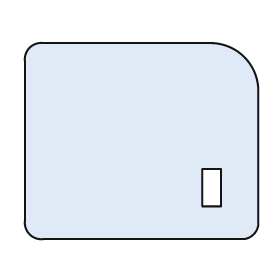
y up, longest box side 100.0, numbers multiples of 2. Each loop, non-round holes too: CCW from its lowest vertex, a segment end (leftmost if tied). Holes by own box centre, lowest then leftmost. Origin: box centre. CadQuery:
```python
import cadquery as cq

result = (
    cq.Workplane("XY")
    .moveTo(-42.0, -42.0)
    .lineTo(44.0, -42.0)
    .threePointArc((48.0, -40.0), (50.0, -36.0))
    .lineTo(50.0, 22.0)
    .threePointArc((44.0, 36.0), (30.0, 42.0))
    .lineTo(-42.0, 42.0)
    .threePointArc((-48.0, 40.0), (-50.0, 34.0))
    .lineTo(-50.0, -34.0)
    .threePointArc((-48.0, -40.0), (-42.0, -42.0))
    .close()
    .moveTo(26.0, -28.0)
    .lineTo(34.0, -28.0)
    .lineTo(34.0, -12.0)
    .lineTo(26.0, -12.0)
    .close()
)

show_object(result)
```